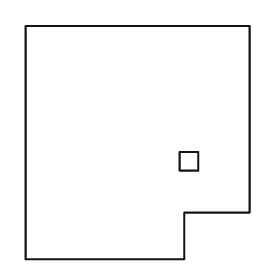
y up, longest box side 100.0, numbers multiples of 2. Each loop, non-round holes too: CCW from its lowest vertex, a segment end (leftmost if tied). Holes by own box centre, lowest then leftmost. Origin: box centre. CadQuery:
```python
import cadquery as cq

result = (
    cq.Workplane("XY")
    .moveTo(-48.0, -50.0)
    .lineTo(20.0, -50.0)
    .lineTo(20.0, -30.0)
    .lineTo(48.0, -30.0)
    .lineTo(48.0, 50.0)
    .lineTo(-48.0, 50.0)
    .close()
    .moveTo(18.0, -12.0)
    .lineTo(26.0, -12.0)
    .lineTo(26.0, -4.0)
    .lineTo(18.0, -4.0)
    .close()
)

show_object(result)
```